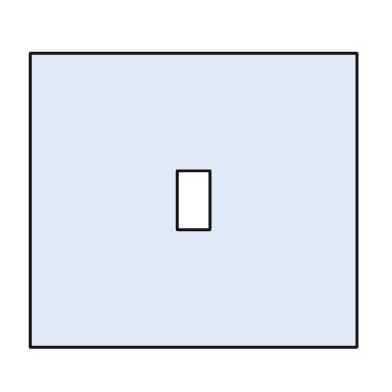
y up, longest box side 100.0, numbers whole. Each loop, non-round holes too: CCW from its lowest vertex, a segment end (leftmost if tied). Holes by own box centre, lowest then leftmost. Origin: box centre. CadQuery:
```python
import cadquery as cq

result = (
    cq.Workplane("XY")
    .moveTo(-50.0, -45.0)
    .lineTo(50.0, -45.0)
    .lineTo(50.0, 45.0)
    .lineTo(-50.0, 45.0)
    .close()
    .moveTo(-5.0, -9.0)
    .lineTo(5.0, -9.0)
    .lineTo(5.0, 9.0)
    .lineTo(-5.0, 9.0)
    .close()
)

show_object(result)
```